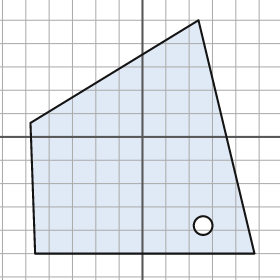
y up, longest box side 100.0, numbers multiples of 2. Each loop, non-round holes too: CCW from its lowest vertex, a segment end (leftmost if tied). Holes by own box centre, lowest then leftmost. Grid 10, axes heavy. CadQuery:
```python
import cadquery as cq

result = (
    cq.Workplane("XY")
    .moveTo(-46.0, -50.0)
    .lineTo(48.0, -50.0)
    .lineTo(24.0, 50.0)
    .lineTo(-48.0, 6.0)
    .close()
    .moveTo(26.0, -38.0)
    .circle(4.0)
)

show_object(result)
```